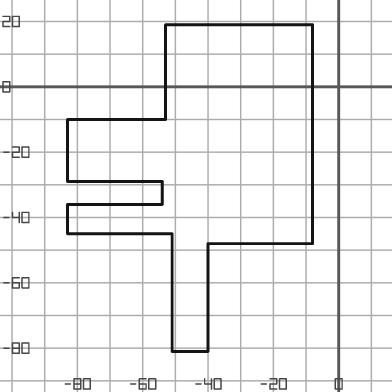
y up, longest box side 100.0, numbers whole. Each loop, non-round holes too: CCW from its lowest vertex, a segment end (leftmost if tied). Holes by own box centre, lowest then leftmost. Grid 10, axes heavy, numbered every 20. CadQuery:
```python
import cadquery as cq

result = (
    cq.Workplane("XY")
    .moveTo(-51.0, -81.0)
    .lineTo(-40.0, -81.0)
    .lineTo(-40.0, -48.0)
    .lineTo(-8.0, -48.0)
    .lineTo(-8.0, 19.0)
    .lineTo(-53.0, 19.0)
    .lineTo(-53.0, -10.0)
    .lineTo(-83.0, -10.0)
    .lineTo(-83.0, -29.0)
    .lineTo(-54.0, -29.0)
    .lineTo(-54.0, -36.0)
    .lineTo(-83.0, -36.0)
    .lineTo(-83.0, -45.0)
    .lineTo(-51.0, -45.0)
    .close()
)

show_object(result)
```